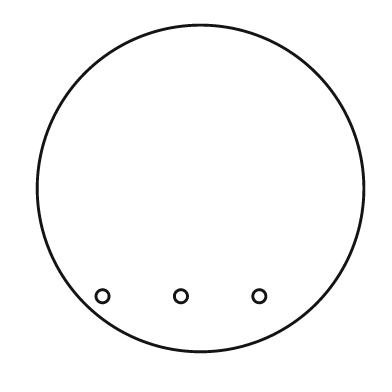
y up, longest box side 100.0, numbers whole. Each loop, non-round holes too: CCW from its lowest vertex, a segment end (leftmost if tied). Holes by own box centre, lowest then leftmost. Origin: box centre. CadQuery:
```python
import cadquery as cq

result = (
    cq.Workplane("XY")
    .moveTo(0.0, 0.0)
    .circle(50.0)
    .moveTo(-30.0, -33.0)
    .circle(2.0)
    .moveTo(-6.0, -33.0)
    .circle(2.0)
    .moveTo(18.0, -33.0)
    .circle(2.0)
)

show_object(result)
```